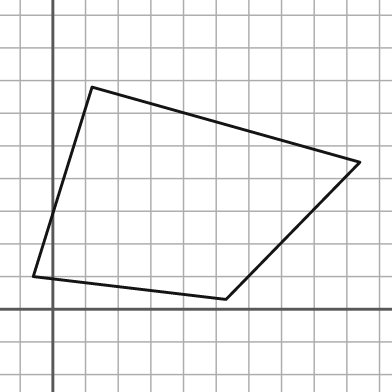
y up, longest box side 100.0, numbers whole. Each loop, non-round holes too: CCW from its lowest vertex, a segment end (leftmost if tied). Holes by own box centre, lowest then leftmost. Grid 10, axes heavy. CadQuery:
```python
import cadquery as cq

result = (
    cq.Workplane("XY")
    .moveTo(53.0, 3.0)
    .lineTo(94.0, 45.0)
    .lineTo(12.0, 68.0)
    .lineTo(-6.0, 10.0)
    .close()
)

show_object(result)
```